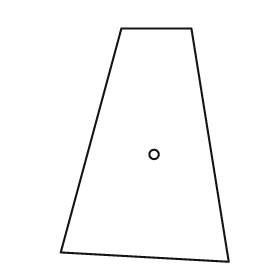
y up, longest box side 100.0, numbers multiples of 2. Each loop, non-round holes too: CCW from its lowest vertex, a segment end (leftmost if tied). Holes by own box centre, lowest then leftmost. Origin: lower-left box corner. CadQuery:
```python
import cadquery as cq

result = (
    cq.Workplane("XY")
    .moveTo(72.0, 0.0)
    .lineTo(56.0, 100.0)
    .lineTo(26.0, 100.0)
    .lineTo(0.0, 4.0)
    .close()
    .moveTo(40.0, 46.0)
    .circle(2.0)
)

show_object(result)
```